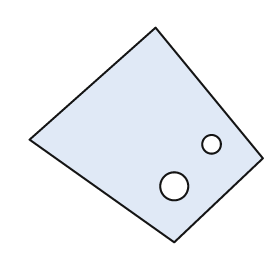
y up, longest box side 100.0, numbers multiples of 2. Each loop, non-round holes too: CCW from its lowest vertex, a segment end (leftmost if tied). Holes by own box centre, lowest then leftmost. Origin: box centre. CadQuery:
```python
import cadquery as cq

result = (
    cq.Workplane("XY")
    .moveTo(12.0, -46.0)
    .lineTo(50.0, -10.0)
    .lineTo(4.0, 46.0)
    .lineTo(-50.0, -2.0)
    .close()
    .moveTo(12.0, -22.0)
    .circle(6.0)
    .moveTo(28.0, -4.0)
    .circle(4.0)
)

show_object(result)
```